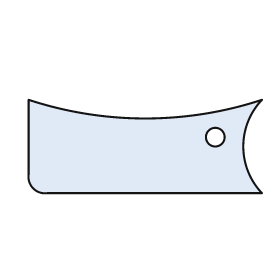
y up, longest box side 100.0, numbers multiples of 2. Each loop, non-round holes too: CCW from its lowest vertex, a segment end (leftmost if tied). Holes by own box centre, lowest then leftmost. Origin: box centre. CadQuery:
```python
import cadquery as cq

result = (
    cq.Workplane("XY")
    .moveTo(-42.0, -20.0)
    .lineTo(50.0, -20.0)
    .threePointArc((42.0, 0.0), (50.0, 20.0))
    .threePointArc((0.0, 12.0), (-50.0, 20.0))
    .lineTo(-50.0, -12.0)
    .threePointArc((-48.0, -18.0), (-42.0, -20.0))
    .close()
    .moveTo(30.0, 4.0)
    .circle(4.0)
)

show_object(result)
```